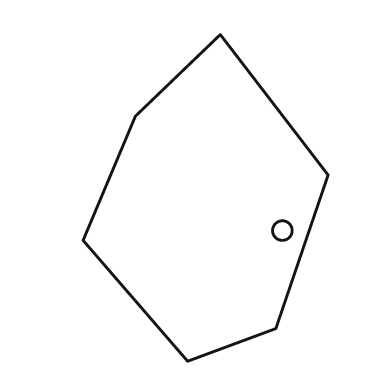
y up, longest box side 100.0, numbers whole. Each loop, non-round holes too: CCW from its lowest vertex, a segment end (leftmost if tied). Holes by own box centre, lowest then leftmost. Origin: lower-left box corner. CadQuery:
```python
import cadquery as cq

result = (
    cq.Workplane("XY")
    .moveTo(32.0, 0.0)
    .lineTo(59.0, 10.0)
    .lineTo(75.0, 57.0)
    .lineTo(42.0, 100.0)
    .lineTo(16.0, 75.0)
    .lineTo(0.0, 37.0)
    .close()
    .moveTo(61.0, 40.0)
    .circle(3.0)
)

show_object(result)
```